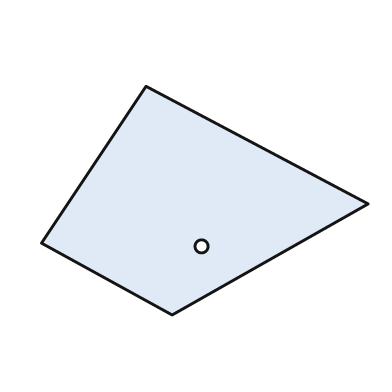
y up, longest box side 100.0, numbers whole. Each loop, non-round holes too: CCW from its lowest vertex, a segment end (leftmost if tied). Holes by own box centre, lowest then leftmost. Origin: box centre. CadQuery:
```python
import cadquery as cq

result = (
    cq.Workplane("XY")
    .moveTo(-10.0, -35.0)
    .lineTo(50.0, -1.0)
    .lineTo(-18.0, 35.0)
    .lineTo(-50.0, -13.0)
    .close()
    .moveTo(-1.0, -14.0)
    .circle(2.0)
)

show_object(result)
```